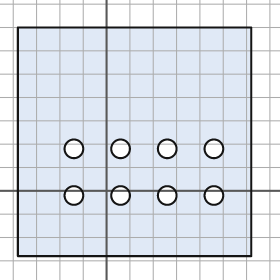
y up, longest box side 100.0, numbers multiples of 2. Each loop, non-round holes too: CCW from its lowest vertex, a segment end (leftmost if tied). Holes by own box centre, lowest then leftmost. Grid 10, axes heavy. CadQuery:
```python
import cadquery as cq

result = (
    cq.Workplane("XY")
    .moveTo(-38.0, -28.0)
    .lineTo(62.0, -28.0)
    .lineTo(62.0, 70.0)
    .lineTo(-38.0, 70.0)
    .close()
    .moveTo(-14.0, -2.0)
    .circle(4.0)
    .moveTo(6.0, -2.0)
    .circle(4.0)
    .moveTo(26.0, -2.0)
    .circle(4.0)
    .moveTo(46.0, -2.0)
    .circle(4.0)
    .moveTo(-14.0, 18.0)
    .circle(4.0)
    .moveTo(6.0, 18.0)
    .circle(4.0)
    .moveTo(26.0, 18.0)
    .circle(4.0)
    .moveTo(46.0, 18.0)
    .circle(4.0)
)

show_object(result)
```